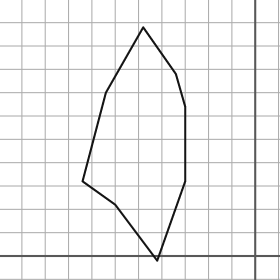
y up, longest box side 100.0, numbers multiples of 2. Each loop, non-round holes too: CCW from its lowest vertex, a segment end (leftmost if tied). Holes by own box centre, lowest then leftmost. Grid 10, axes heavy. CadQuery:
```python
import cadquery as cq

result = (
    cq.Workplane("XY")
    .moveTo(-42.0, -2.0)
    .lineTo(-30.0, 32.0)
    .lineTo(-30.0, 64.0)
    .lineTo(-34.0, 78.0)
    .lineTo(-48.0, 98.0)
    .lineTo(-64.0, 70.0)
    .lineTo(-74.0, 32.0)
    .lineTo(-60.0, 22.0)
    .close()
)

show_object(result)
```